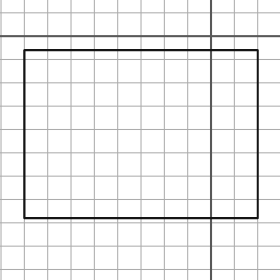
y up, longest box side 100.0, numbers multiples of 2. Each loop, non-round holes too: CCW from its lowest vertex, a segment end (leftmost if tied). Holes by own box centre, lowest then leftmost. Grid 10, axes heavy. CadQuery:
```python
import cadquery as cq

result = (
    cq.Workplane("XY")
    .moveTo(-80.0, -78.0)
    .lineTo(20.0, -78.0)
    .lineTo(20.0, -6.0)
    .lineTo(-80.0, -6.0)
    .close()
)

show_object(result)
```